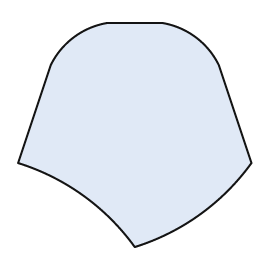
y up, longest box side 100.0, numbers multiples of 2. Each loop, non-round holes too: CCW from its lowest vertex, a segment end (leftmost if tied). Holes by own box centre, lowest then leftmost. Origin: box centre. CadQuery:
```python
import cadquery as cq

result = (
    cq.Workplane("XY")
    .moveTo(0.0, -48.0)
    .threePointArc((28.0, -34.0), (50.0, -12.0))
    .lineTo(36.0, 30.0)
    .threePointArc((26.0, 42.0), (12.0, 48.0))
    .lineTo(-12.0, 48.0)
    .threePointArc((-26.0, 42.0), (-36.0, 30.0))
    .lineTo(-50.0, -12.0)
    .threePointArc((-22.0, -26.0), (0.0, -48.0))
    .close()
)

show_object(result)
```